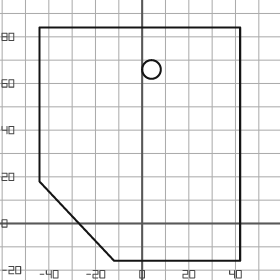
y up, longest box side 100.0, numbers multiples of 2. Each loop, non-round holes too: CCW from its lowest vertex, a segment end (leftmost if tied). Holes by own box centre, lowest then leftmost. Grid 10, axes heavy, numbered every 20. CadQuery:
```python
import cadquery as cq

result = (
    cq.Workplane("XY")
    .moveTo(-12.0, -16.0)
    .lineTo(42.0, -16.0)
    .lineTo(42.0, 84.0)
    .lineTo(-44.0, 84.0)
    .lineTo(-44.0, 18.0)
    .close()
    .moveTo(4.0, 66.0)
    .circle(4.0)
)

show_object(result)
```